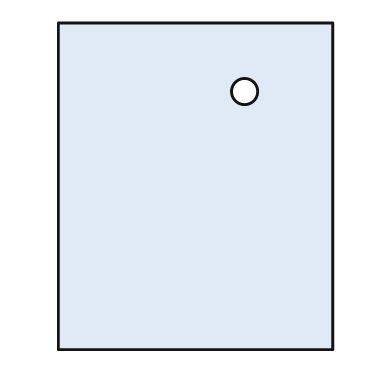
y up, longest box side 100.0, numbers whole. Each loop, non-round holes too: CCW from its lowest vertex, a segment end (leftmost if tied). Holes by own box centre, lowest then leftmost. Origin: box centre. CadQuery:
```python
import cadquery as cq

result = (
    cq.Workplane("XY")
    .moveTo(-42.0, -50.0)
    .lineTo(42.0, -50.0)
    .lineTo(42.0, 50.0)
    .lineTo(-42.0, 50.0)
    .close()
    .moveTo(15.0, 29.0)
    .circle(4.0)
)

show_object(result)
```